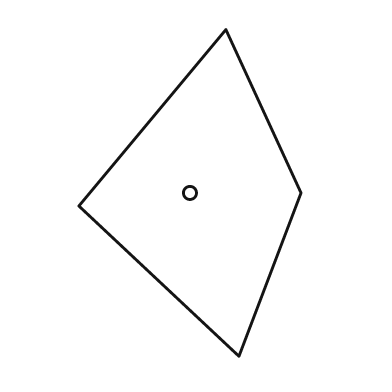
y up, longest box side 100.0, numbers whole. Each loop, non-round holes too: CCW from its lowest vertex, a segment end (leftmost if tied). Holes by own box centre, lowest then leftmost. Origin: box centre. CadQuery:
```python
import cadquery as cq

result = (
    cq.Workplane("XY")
    .moveTo(15.0, -50.0)
    .lineTo(34.0, 0.0)
    .lineTo(11.0, 50.0)
    .lineTo(-34.0, -4.0)
    .close()
    .moveTo(0.0, 0.0)
    .circle(2.0)
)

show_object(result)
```